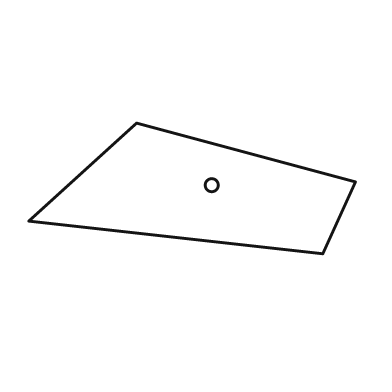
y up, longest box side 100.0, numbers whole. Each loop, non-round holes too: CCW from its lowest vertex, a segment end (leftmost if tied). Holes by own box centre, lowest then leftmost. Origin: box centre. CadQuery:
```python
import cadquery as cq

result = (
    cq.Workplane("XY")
    .moveTo(40.0, -20.0)
    .lineTo(50.0, 2.0)
    .lineTo(-17.0, 20.0)
    .lineTo(-50.0, -10.0)
    .close()
    .moveTo(6.0, 1.0)
    .circle(2.0)
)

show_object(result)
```